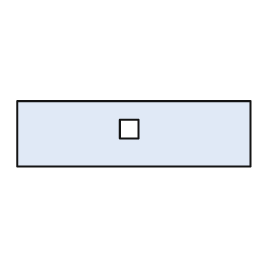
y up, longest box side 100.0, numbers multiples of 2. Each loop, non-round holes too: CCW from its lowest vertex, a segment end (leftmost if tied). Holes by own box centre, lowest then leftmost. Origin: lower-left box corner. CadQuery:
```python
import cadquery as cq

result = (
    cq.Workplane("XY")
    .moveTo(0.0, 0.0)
    .lineTo(100.0, 0.0)
    .lineTo(100.0, 28.0)
    .lineTo(0.0, 28.0)
    .close()
    .moveTo(44.0, 12.0)
    .lineTo(52.0, 12.0)
    .lineTo(52.0, 20.0)
    .lineTo(44.0, 20.0)
    .close()
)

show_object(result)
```